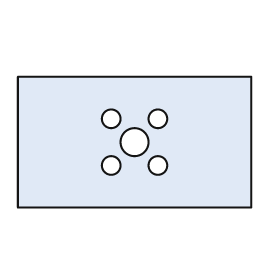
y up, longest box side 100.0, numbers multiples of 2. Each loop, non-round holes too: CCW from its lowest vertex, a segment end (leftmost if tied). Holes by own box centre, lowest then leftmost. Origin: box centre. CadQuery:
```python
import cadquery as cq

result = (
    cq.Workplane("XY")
    .moveTo(-50.0, -28.0)
    .lineTo(50.0, -28.0)
    .lineTo(50.0, 28.0)
    .lineTo(-50.0, 28.0)
    .close()
    .moveTo(-10.0, -10.0)
    .circle(4.0)
    .moveTo(10.0, -10.0)
    .circle(4.0)
    .moveTo(0.0, 0.0)
    .circle(6.0)
    .moveTo(-10.0, 10.0)
    .circle(4.0)
    .moveTo(10.0, 10.0)
    .circle(4.0)
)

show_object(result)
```